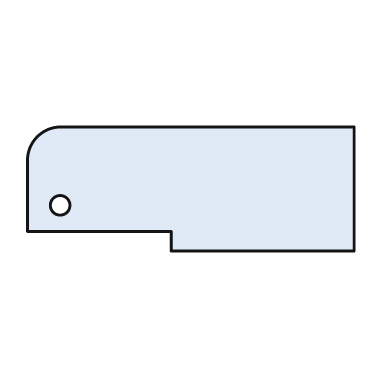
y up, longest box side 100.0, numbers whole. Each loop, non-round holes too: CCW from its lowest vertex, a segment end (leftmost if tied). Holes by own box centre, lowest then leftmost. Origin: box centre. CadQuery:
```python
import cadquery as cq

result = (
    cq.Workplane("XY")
    .moveTo(-6.0, -19.0)
    .lineTo(50.0, -19.0)
    .lineTo(50.0, 19.0)
    .lineTo(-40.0, 19.0)
    .threePointArc((-47.0, 16.0), (-50.0, 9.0))
    .lineTo(-50.0, -13.0)
    .lineTo(-6.0, -13.0)
    .close()
    .moveTo(-40.0, -5.0)
    .circle(3.0)
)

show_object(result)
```